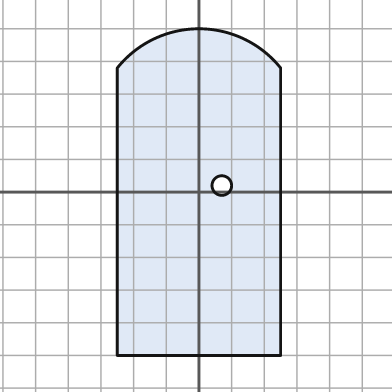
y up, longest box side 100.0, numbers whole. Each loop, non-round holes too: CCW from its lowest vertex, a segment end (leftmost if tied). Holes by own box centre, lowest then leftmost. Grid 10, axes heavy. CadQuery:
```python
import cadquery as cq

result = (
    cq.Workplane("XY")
    .moveTo(-25.0, -50.0)
    .lineTo(25.0, -50.0)
    .lineTo(25.0, 38.0)
    .threePointArc((0.0, 50.0), (-25.0, 38.0))
    .close()
    .moveTo(7.0, 2.0)
    .circle(3.0)
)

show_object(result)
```